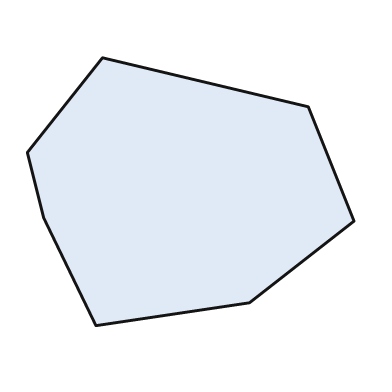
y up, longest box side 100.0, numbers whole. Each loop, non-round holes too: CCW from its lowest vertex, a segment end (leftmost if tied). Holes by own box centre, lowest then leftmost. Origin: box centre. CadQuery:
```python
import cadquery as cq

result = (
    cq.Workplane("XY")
    .moveTo(-29.0, -41.0)
    .lineTo(18.0, -34.0)
    .lineTo(50.0, -9.0)
    .lineTo(36.0, 26.0)
    .lineTo(-27.0, 41.0)
    .lineTo(-50.0, 12.0)
    .lineTo(-45.0, -8.0)
    .close()
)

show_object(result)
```